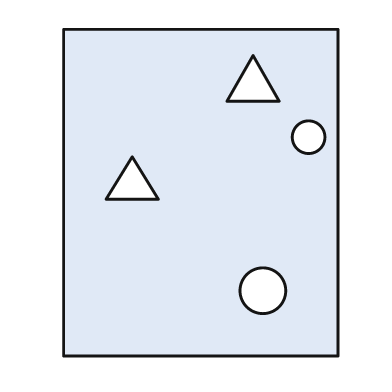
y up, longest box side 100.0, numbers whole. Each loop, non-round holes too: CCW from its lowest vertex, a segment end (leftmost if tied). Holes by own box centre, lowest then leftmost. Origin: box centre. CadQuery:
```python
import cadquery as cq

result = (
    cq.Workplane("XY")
    .moveTo(-42.0, -50.0)
    .lineTo(42.0, -50.0)
    .lineTo(42.0, 50.0)
    .lineTo(-42.0, 50.0)
    .close()
    .moveTo(19.0, -30.0)
    .circle(7.0)
    .moveTo(-29.0, -2.0)
    .lineTo(-13.0, -2.0)
    .lineTo(-21.0, 11.0)
    .close()
    .moveTo(33.0, 17.0)
    .circle(5.0)
    .moveTo(8.0, 28.0)
    .lineTo(24.0, 28.0)
    .lineTo(16.0, 42.0)
    .close()
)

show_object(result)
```